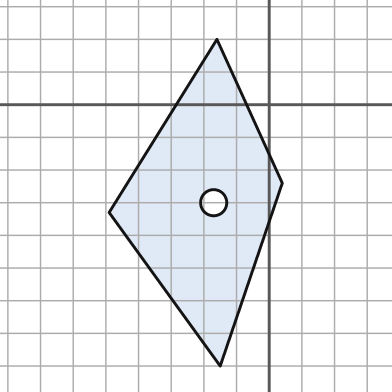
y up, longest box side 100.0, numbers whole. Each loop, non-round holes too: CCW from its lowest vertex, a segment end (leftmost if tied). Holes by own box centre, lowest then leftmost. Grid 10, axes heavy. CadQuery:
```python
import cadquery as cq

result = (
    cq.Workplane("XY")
    .moveTo(-15.0, -80.0)
    .lineTo(4.0, -24.0)
    .lineTo(-16.0, 20.0)
    .lineTo(-49.0, -33.0)
    .close()
    .moveTo(-17.0, -30.0)
    .circle(4.0)
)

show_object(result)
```